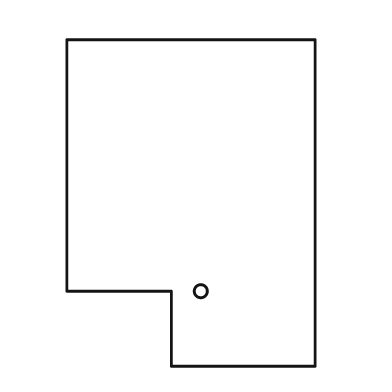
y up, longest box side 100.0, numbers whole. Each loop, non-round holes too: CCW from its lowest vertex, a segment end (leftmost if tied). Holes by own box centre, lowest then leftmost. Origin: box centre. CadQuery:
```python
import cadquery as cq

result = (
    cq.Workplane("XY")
    .moveTo(-6.0, -50.0)
    .lineTo(38.0, -50.0)
    .lineTo(38.0, 50.0)
    .lineTo(-38.0, 50.0)
    .lineTo(-38.0, -27.0)
    .lineTo(-6.0, -27.0)
    .close()
    .moveTo(3.0, -27.0)
    .circle(2.0)
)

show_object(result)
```